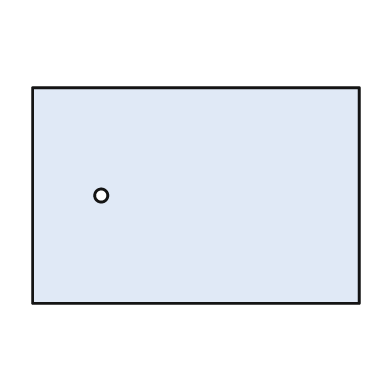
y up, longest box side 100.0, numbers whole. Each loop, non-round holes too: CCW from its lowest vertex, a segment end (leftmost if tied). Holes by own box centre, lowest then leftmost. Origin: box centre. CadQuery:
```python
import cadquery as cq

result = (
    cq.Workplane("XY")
    .moveTo(-50.0, -33.0)
    .lineTo(50.0, -33.0)
    .lineTo(50.0, 33.0)
    .lineTo(-50.0, 33.0)
    .close()
    .moveTo(-29.0, 0.0)
    .circle(2.0)
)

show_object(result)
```